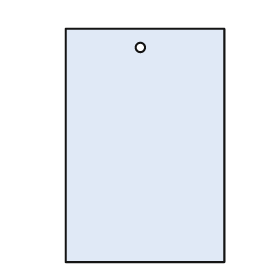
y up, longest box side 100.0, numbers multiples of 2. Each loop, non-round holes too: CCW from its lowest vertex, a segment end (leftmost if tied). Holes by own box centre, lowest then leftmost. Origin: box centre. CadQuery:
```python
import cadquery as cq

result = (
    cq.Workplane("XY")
    .moveTo(-34.0, -50.0)
    .lineTo(34.0, -50.0)
    .lineTo(34.0, 50.0)
    .lineTo(-34.0, 50.0)
    .close()
    .moveTo(-2.0, 42.0)
    .circle(2.0)
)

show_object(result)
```